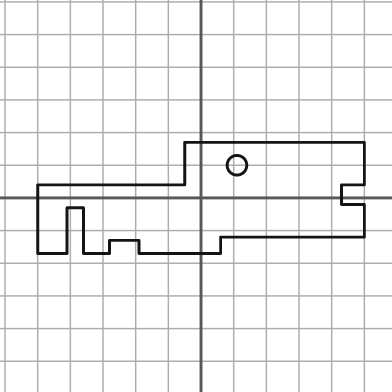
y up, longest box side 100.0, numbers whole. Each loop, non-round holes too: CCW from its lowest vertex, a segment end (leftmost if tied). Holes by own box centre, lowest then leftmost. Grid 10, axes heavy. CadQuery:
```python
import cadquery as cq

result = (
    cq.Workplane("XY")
    .moveTo(-50.0, -17.0)
    .lineTo(-41.0, -17.0)
    .lineTo(-41.0, -3.0)
    .lineTo(-36.0, -3.0)
    .lineTo(-36.0, -17.0)
    .lineTo(-28.0, -17.0)
    .lineTo(-28.0, -13.0)
    .lineTo(-19.0, -13.0)
    .lineTo(-19.0, -17.0)
    .lineTo(6.0, -17.0)
    .lineTo(6.0, -12.0)
    .lineTo(50.0, -12.0)
    .lineTo(50.0, -2.0)
    .lineTo(43.0, -2.0)
    .lineTo(43.0, 4.0)
    .lineTo(50.0, 4.0)
    .lineTo(50.0, 17.0)
    .lineTo(-5.0, 17.0)
    .lineTo(-5.0, 4.0)
    .lineTo(-50.0, 4.0)
    .close()
    .moveTo(11.0, 10.0)
    .circle(3.0)
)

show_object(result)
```